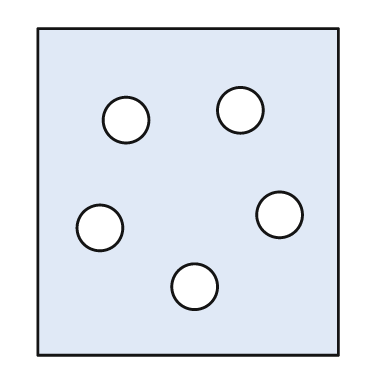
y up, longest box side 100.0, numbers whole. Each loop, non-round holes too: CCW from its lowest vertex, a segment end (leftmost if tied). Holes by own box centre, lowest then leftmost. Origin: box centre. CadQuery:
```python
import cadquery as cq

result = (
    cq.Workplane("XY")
    .moveTo(-46.0, -50.0)
    .lineTo(46.0, -50.0)
    .lineTo(46.0, 50.0)
    .lineTo(-46.0, 50.0)
    .close()
    .moveTo(2.0, -29.0)
    .circle(7.0)
    .moveTo(-27.0, -11.0)
    .circle(7.0)
    .moveTo(28.0, -7.0)
    .circle(7.0)
    .moveTo(-19.0, 22.0)
    .circle(7.0)
    .moveTo(16.0, 25.0)
    .circle(7.0)
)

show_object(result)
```